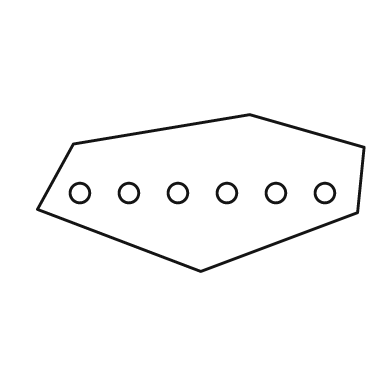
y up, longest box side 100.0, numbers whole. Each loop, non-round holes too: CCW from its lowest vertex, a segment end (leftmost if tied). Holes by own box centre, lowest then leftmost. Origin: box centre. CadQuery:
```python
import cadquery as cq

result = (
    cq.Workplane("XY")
    .moveTo(0.0, -24.0)
    .lineTo(48.0, -6.0)
    .lineTo(50.0, 14.0)
    .lineTo(15.0, 24.0)
    .lineTo(-39.0, 15.0)
    .lineTo(-50.0, -5.0)
    .close()
    .moveTo(-37.0, 0.0)
    .circle(3.0)
    .moveTo(-22.0, 0.0)
    .circle(3.0)
    .moveTo(-7.0, 0.0)
    .circle(3.0)
    .moveTo(8.0, 0.0)
    .circle(3.0)
    .moveTo(23.0, 0.0)
    .circle(3.0)
    .moveTo(38.0, 0.0)
    .circle(3.0)
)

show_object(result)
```